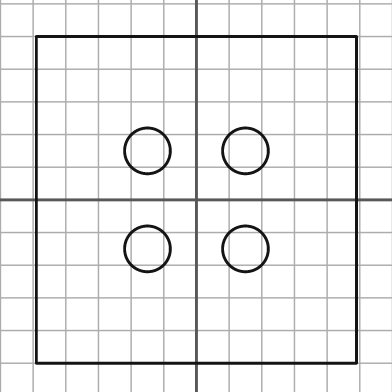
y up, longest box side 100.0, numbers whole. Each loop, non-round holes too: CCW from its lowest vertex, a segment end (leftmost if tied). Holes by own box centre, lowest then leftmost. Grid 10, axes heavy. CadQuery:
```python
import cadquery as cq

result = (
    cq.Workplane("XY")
    .moveTo(-49.0, -50.0)
    .lineTo(49.0, -50.0)
    .lineTo(49.0, 50.0)
    .lineTo(-49.0, 50.0)
    .close()
    .moveTo(-15.0, -15.0)
    .circle(7.0)
    .moveTo(15.0, -15.0)
    .circle(7.0)
    .moveTo(-15.0, 15.0)
    .circle(7.0)
    .moveTo(15.0, 15.0)
    .circle(7.0)
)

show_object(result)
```